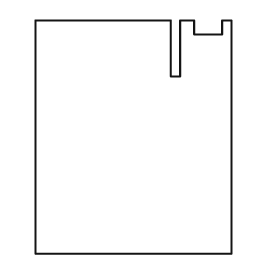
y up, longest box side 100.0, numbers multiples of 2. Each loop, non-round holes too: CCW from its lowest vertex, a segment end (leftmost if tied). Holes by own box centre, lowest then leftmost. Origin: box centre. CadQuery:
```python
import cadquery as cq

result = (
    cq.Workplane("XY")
    .moveTo(-42.0, -50.0)
    .lineTo(42.0, -50.0)
    .lineTo(42.0, 50.0)
    .lineTo(38.0, 50.0)
    .lineTo(38.0, 44.0)
    .lineTo(26.0, 44.0)
    .lineTo(26.0, 50.0)
    .lineTo(20.0, 50.0)
    .lineTo(20.0, 26.0)
    .lineTo(16.0, 26.0)
    .lineTo(16.0, 50.0)
    .lineTo(-42.0, 50.0)
    .close()
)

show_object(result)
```